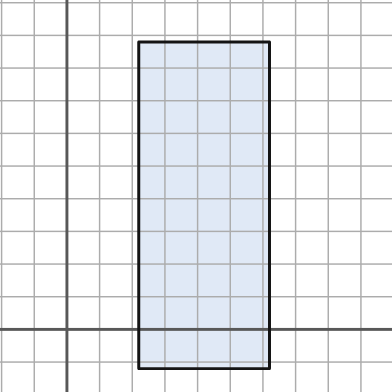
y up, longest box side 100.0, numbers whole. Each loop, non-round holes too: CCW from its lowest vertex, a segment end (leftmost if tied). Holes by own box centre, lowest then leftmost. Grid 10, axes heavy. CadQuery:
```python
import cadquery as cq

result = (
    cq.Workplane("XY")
    .moveTo(22.0, -12.0)
    .lineTo(62.0, -12.0)
    .lineTo(62.0, 88.0)
    .lineTo(22.0, 88.0)
    .close()
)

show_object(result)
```